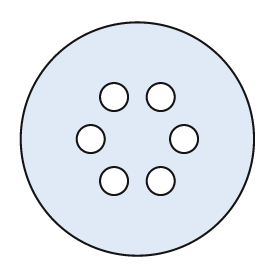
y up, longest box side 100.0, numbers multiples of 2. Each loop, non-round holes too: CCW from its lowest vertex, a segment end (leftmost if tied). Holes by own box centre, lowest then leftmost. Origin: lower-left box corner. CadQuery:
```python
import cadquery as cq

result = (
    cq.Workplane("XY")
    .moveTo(50.0, 50.0)
    .circle(50.0)
    .moveTo(40.0, 32.0)
    .circle(6.0)
    .moveTo(60.0, 32.0)
    .circle(6.0)
    .moveTo(30.0, 50.0)
    .circle(6.0)
    .moveTo(70.0, 50.0)
    .circle(6.0)
    .moveTo(40.0, 68.0)
    .circle(6.0)
    .moveTo(60.0, 68.0)
    .circle(6.0)
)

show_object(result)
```